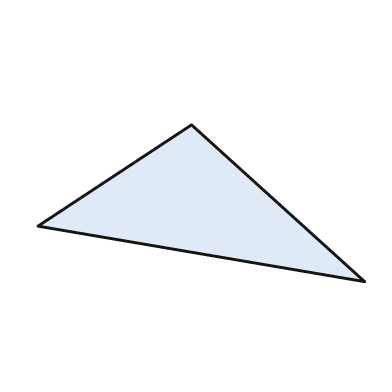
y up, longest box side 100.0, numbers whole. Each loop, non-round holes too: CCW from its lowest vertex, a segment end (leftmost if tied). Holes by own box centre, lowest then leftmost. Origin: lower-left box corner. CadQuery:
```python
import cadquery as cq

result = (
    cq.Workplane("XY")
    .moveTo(100.0, 0.0)
    .lineTo(47.0, 48.0)
    .lineTo(0.0, 17.0)
    .close()
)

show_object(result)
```